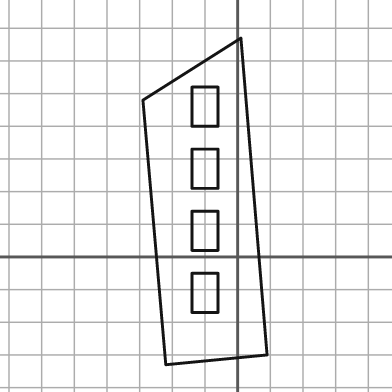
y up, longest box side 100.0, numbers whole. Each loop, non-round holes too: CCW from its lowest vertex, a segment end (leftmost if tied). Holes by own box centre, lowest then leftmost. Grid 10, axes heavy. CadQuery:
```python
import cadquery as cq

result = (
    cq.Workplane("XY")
    .moveTo(-22.0, -33.0)
    .lineTo(9.0, -30.0)
    .lineTo(1.0, 67.0)
    .lineTo(-29.0, 48.0)
    .close()
    .moveTo(-14.0, -17.0)
    .lineTo(-6.0, -17.0)
    .lineTo(-6.0, -5.0)
    .lineTo(-14.0, -5.0)
    .close()
    .moveTo(-14.0, 2.0)
    .lineTo(-6.0, 2.0)
    .lineTo(-6.0, 14.0)
    .lineTo(-14.0, 14.0)
    .close()
    .moveTo(-14.0, 21.0)
    .lineTo(-6.0, 21.0)
    .lineTo(-6.0, 33.0)
    .lineTo(-14.0, 33.0)
    .close()
    .moveTo(-14.0, 40.0)
    .lineTo(-6.0, 40.0)
    .lineTo(-6.0, 52.0)
    .lineTo(-14.0, 52.0)
    .close()
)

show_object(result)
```